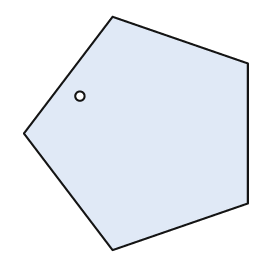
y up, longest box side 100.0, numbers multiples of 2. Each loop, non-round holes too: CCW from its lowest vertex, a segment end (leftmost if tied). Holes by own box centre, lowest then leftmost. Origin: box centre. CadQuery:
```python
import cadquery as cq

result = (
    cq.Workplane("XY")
    .moveTo(-10.0, -50.0)
    .lineTo(48.0, -30.0)
    .lineTo(48.0, 30.0)
    .lineTo(-10.0, 50.0)
    .lineTo(-48.0, 0.0)
    .close()
    .moveTo(-24.0, 16.0)
    .circle(2.0)
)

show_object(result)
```